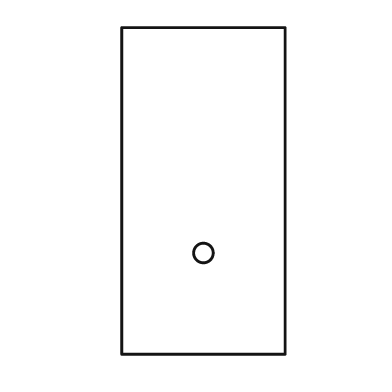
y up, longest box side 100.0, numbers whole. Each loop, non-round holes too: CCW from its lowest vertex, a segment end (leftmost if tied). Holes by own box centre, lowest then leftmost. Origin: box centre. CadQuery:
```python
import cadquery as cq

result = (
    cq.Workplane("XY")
    .moveTo(-25.0, -50.0)
    .lineTo(25.0, -50.0)
    .lineTo(25.0, 50.0)
    .lineTo(-25.0, 50.0)
    .close()
    .moveTo(0.0, -19.0)
    .circle(3.0)
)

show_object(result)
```